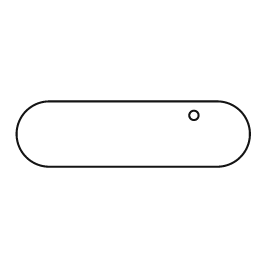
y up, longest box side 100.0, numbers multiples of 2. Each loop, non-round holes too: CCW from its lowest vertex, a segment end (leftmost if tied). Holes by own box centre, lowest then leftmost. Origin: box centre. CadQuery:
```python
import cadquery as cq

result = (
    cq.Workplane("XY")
    .moveTo(-36.0, -14.0)
    .lineTo(36.0, -14.0)
    .threePointArc((50.0, 0.0), (36.0, 14.0))
    .lineTo(-36.0, 14.0)
    .threePointArc((-50.0, 0.0), (-36.0, -14.0))
    .close()
    .moveTo(26.0, 8.0)
    .circle(2.0)
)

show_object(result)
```